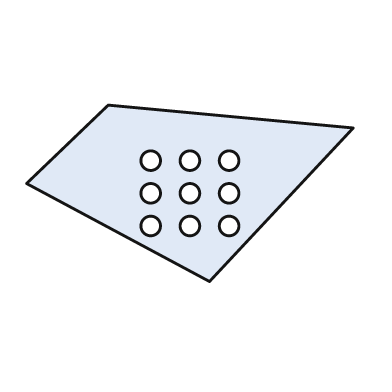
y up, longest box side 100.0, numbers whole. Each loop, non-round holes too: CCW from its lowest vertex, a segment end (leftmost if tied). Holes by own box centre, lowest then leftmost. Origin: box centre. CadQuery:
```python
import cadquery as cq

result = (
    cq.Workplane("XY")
    .moveTo(6.0, -27.0)
    .lineTo(50.0, 20.0)
    .lineTo(-25.0, 27.0)
    .lineTo(-50.0, 3.0)
    .close()
    .moveTo(-12.0, -10.0)
    .circle(3.0)
    .moveTo(0.0, -10.0)
    .circle(3.0)
    .moveTo(12.0, -10.0)
    .circle(3.0)
    .moveTo(-12.0, 0.0)
    .circle(3.0)
    .moveTo(0.0, 0.0)
    .circle(3.0)
    .moveTo(12.0, 0.0)
    .circle(3.0)
    .moveTo(-12.0, 10.0)
    .circle(3.0)
    .moveTo(0.0, 10.0)
    .circle(3.0)
    .moveTo(12.0, 10.0)
    .circle(3.0)
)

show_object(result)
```